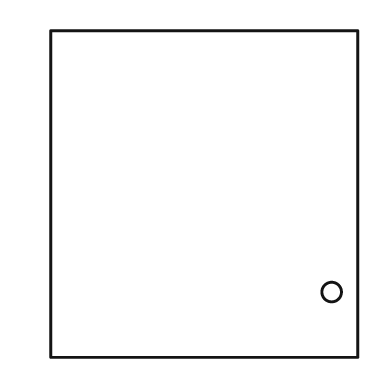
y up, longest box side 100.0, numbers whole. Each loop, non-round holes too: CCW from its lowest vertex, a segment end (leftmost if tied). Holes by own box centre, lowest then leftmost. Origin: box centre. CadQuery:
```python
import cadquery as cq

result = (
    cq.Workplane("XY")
    .moveTo(-47.0, -50.0)
    .lineTo(47.0, -50.0)
    .lineTo(47.0, 50.0)
    .lineTo(-47.0, 50.0)
    .close()
    .moveTo(39.0, -30.0)
    .circle(3.0)
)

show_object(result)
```